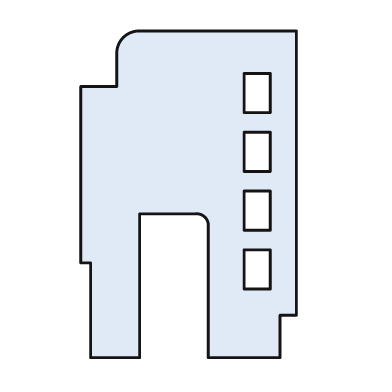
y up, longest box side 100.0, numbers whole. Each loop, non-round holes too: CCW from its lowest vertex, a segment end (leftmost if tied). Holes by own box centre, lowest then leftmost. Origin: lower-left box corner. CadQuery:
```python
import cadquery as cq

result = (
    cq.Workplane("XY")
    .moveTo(3.0, 0.0)
    .lineTo(18.0, 0.0)
    .lineTo(18.0, 44.0)
    .lineTo(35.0, 44.0)
    .threePointArc((38.0, 43.0), (39.0, 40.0))
    .lineTo(39.0, 0.0)
    .lineTo(61.0, 0.0)
    .lineTo(61.0, 13.0)
    .lineTo(66.0, 13.0)
    .lineTo(66.0, 100.0)
    .lineTo(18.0, 100.0)
    .threePointArc((13.0, 98.0), (11.0, 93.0))
    .lineTo(11.0, 83.0)
    .lineTo(0.0, 83.0)
    .lineTo(0.0, 29.0)
    .lineTo(3.0, 29.0)
    .close()
    .moveTo(50.0, 21.0)
    .lineTo(58.0, 21.0)
    .lineTo(58.0, 33.0)
    .lineTo(50.0, 33.0)
    .close()
    .moveTo(50.0, 39.0)
    .lineTo(58.0, 39.0)
    .lineTo(58.0, 51.0)
    .lineTo(50.0, 51.0)
    .close()
    .moveTo(50.0, 57.0)
    .lineTo(58.0, 57.0)
    .lineTo(58.0, 69.0)
    .lineTo(50.0, 69.0)
    .close()
    .moveTo(50.0, 75.0)
    .lineTo(58.0, 75.0)
    .lineTo(58.0, 87.0)
    .lineTo(50.0, 87.0)
    .close()
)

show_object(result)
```